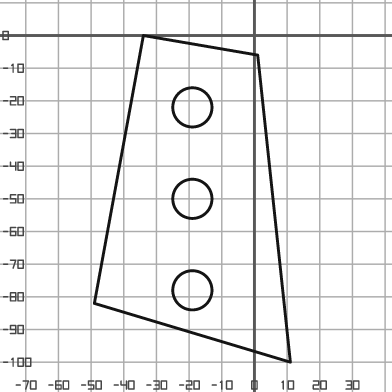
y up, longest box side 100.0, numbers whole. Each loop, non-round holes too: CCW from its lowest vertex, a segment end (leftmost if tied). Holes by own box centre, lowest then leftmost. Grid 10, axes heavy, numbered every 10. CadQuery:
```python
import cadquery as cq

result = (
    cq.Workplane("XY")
    .moveTo(11.0, -100.0)
    .lineTo(1.0, -6.0)
    .lineTo(-34.0, 0.0)
    .lineTo(-49.0, -82.0)
    .close()
    .moveTo(-19.0, -78.0)
    .circle(6.0)
    .moveTo(-19.0, -50.0)
    .circle(6.0)
    .moveTo(-19.0, -22.0)
    .circle(6.0)
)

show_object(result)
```